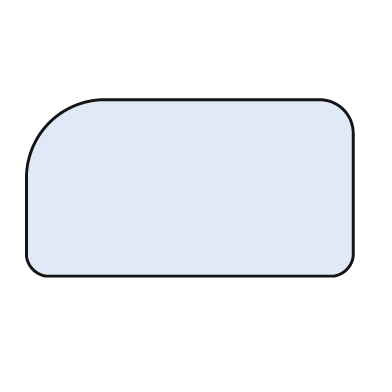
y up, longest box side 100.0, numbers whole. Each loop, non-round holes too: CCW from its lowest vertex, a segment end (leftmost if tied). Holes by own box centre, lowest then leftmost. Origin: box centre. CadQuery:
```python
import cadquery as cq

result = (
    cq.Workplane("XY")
    .moveTo(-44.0, -27.0)
    .lineTo(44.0, -27.0)
    .threePointArc((48.0, -25.0), (50.0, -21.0))
    .lineTo(50.0, 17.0)
    .threePointArc((47.0, 24.0), (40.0, 27.0))
    .lineTo(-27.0, 27.0)
    .threePointArc((-43.0, 20.0), (-50.0, 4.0))
    .lineTo(-50.0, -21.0)
    .threePointArc((-48.0, -25.0), (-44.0, -27.0))
    .close()
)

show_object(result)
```